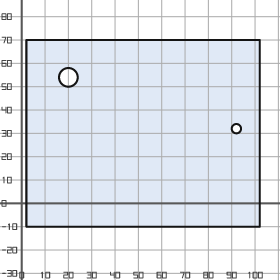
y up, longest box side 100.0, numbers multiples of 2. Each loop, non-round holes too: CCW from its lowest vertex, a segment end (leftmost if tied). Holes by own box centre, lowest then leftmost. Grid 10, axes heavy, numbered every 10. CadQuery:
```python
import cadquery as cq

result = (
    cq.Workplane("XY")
    .moveTo(2.0, -10.0)
    .lineTo(102.0, -10.0)
    .lineTo(102.0, 70.0)
    .lineTo(2.0, 70.0)
    .close()
    .moveTo(92.0, 32.0)
    .circle(2.0)
    .moveTo(20.0, 54.0)
    .circle(4.0)
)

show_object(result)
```